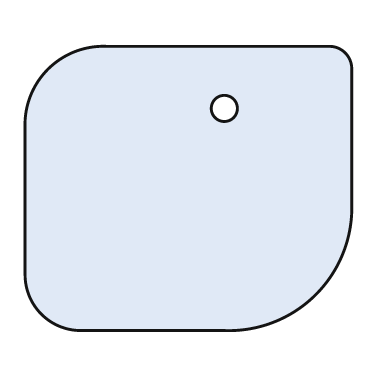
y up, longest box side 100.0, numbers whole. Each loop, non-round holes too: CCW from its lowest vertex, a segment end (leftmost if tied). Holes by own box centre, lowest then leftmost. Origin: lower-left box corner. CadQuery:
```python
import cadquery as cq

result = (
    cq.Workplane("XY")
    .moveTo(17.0, 0.0)
    .lineTo(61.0, 0.0)
    .threePointArc((89.0, 11.0), (100.0, 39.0))
    .lineTo(100.0, 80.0)
    .threePointArc((98.0, 85.0), (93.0, 87.0))
    .lineTo(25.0, 87.0)
    .threePointArc((7.0, 80.0), (0.0, 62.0))
    .lineTo(0.0, 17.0)
    .threePointArc((5.0, 5.0), (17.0, 0.0))
    .close()
    .moveTo(61.0, 68.0)
    .circle(4.0)
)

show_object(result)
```